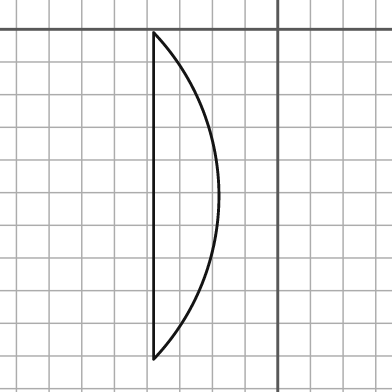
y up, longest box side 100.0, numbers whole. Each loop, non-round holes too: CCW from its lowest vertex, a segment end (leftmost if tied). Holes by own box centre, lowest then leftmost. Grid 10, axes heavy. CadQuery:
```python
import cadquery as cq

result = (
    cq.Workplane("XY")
    .moveTo(-38.0, -101.0)
    .threePointArc((-18.0, -51.0), (-38.0, -1.0))
    .close()
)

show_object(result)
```